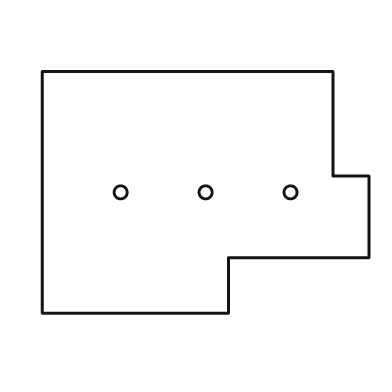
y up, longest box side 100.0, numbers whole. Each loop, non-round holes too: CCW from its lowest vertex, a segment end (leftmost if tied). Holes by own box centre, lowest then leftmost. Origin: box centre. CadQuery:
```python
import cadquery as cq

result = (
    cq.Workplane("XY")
    .moveTo(-50.0, -37.0)
    .lineTo(7.0, -37.0)
    .lineTo(7.0, -20.0)
    .lineTo(50.0, -20.0)
    .lineTo(50.0, 5.0)
    .lineTo(39.0, 5.0)
    .lineTo(39.0, 37.0)
    .lineTo(-50.0, 37.0)
    .close()
    .moveTo(-26.0, 0.0)
    .circle(2.0)
    .moveTo(0.0, 0.0)
    .circle(2.0)
    .moveTo(26.0, 0.0)
    .circle(2.0)
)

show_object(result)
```